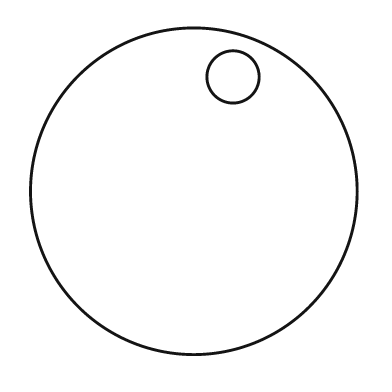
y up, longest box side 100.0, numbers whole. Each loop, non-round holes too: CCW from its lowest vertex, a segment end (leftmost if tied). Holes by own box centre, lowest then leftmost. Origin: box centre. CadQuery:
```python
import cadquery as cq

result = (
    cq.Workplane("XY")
    .moveTo(0.0, 0.0)
    .circle(50.0)
    .moveTo(12.0, 35.0)
    .circle(8.0)
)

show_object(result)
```